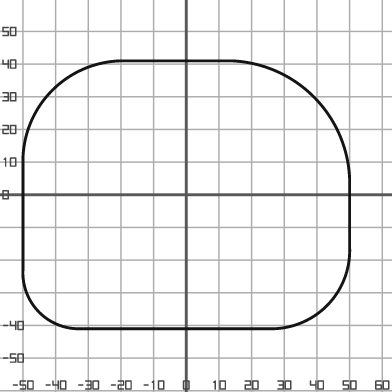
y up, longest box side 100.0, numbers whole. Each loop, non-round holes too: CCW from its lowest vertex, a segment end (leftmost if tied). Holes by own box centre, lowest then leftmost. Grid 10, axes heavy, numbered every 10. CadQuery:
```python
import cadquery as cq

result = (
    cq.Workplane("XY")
    .moveTo(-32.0, -41.0)
    .lineTo(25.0, -41.0)
    .threePointArc((43.0, -34.0), (50.0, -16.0))
    .lineTo(50.0, 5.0)
    .threePointArc((39.0, 30.0), (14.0, 41.0))
    .lineTo(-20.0, 41.0)
    .threePointArc((-41.0, 32.0), (-50.0, 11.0))
    .lineTo(-50.0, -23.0)
    .threePointArc((-45.0, -36.0), (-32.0, -41.0))
    .close()
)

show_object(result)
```